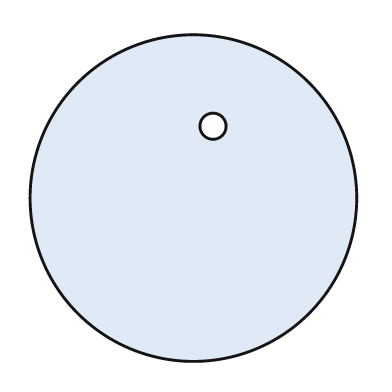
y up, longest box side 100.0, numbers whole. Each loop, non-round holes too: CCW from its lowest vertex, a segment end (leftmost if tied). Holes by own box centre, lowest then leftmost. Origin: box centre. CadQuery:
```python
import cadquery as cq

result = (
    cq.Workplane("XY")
    .moveTo(0.0, 0.0)
    .circle(50.0)
    .moveTo(6.0, 22.0)
    .circle(4.0)
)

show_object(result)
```